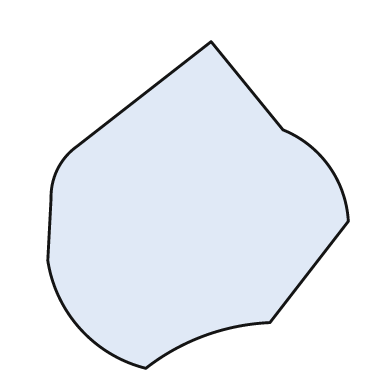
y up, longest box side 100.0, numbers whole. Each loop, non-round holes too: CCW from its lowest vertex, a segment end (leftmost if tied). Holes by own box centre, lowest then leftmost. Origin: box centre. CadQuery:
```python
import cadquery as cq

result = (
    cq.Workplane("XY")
    .moveTo(-16.0, -50.0)
    .threePointArc((2.0, -40.0), (22.0, -36.0))
    .lineTo(46.0, -5.0)
    .threePointArc((40.0, 12.0), (26.0, 23.0))
    .lineTo(4.0, 50.0)
    .lineTo(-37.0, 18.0)
    .threePointArc((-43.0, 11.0), (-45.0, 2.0))
    .lineTo(-46.0, -17.0)
    .threePointArc((-36.0, -38.0), (-16.0, -50.0))
    .close()
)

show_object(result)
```